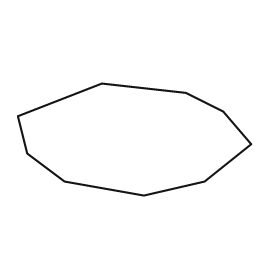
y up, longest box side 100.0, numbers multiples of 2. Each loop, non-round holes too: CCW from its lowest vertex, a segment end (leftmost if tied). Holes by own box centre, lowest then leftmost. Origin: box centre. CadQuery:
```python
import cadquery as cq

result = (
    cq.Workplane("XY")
    .moveTo(4.0, -24.0)
    .lineTo(30.0, -18.0)
    .lineTo(50.0, -2.0)
    .lineTo(38.0, 12.0)
    .lineTo(22.0, 20.0)
    .lineTo(-14.0, 24.0)
    .lineTo(-50.0, 10.0)
    .lineTo(-46.0, -6.0)
    .lineTo(-30.0, -18.0)
    .close()
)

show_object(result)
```